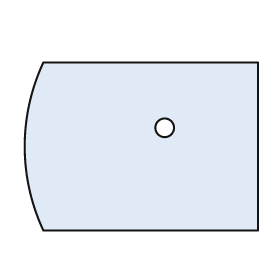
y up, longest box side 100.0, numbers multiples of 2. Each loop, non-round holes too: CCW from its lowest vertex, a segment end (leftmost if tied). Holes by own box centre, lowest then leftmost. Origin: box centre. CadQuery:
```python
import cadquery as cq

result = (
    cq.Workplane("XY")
    .moveTo(-42.0, -36.0)
    .lineTo(50.0, -36.0)
    .lineTo(50.0, 36.0)
    .lineTo(-42.0, 36.0)
    .threePointArc((-50.0, 0.0), (-42.0, -36.0))
    .close()
    .moveTo(10.0, 8.0)
    .circle(4.0)
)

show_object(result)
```